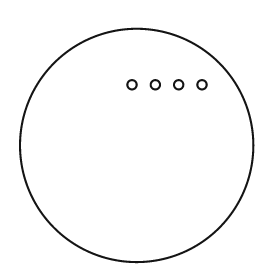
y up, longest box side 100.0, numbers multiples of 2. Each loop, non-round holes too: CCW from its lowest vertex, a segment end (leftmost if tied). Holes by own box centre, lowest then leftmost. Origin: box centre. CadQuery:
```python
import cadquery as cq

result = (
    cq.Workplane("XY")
    .moveTo(0.0, 0.0)
    .circle(50.0)
    .moveTo(-2.0, 26.0)
    .circle(2.0)
    .moveTo(8.0, 26.0)
    .circle(2.0)
    .moveTo(18.0, 26.0)
    .circle(2.0)
    .moveTo(28.0, 26.0)
    .circle(2.0)
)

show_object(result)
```